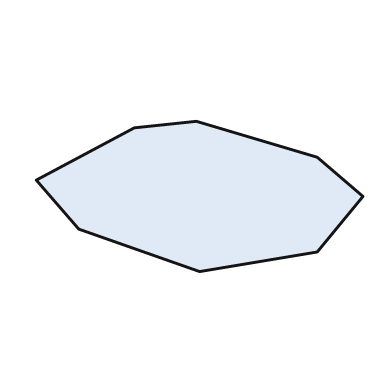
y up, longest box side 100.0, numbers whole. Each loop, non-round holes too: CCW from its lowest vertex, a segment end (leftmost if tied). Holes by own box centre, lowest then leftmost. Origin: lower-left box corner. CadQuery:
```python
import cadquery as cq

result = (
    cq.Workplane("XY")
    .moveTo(50.0, 0.0)
    .lineTo(86.0, 6.0)
    .lineTo(100.0, 23.0)
    .lineTo(86.0, 35.0)
    .lineTo(49.0, 46.0)
    .lineTo(30.0, 44.0)
    .lineTo(0.0, 28.0)
    .lineTo(13.0, 13.0)
    .close()
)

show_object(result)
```